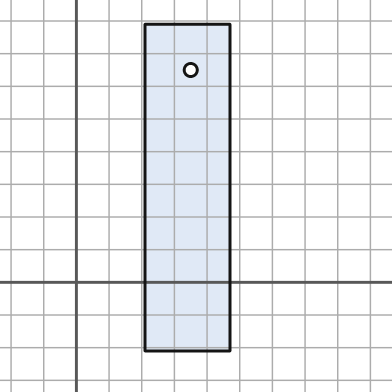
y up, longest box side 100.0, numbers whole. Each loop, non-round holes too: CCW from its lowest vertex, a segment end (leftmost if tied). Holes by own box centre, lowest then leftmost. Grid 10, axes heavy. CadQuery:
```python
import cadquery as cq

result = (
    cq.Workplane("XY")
    .moveTo(21.0, -21.0)
    .lineTo(47.0, -21.0)
    .lineTo(47.0, 79.0)
    .lineTo(21.0, 79.0)
    .close()
    .moveTo(35.0, 65.0)
    .circle(2.0)
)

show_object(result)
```